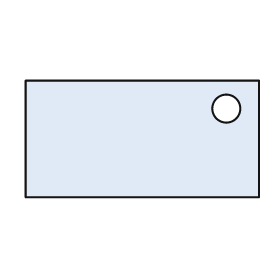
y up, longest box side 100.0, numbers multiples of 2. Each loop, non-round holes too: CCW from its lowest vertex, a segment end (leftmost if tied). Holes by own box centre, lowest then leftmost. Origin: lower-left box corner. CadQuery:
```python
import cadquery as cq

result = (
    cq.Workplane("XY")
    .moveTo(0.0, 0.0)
    .lineTo(100.0, 0.0)
    .lineTo(100.0, 50.0)
    .lineTo(0.0, 50.0)
    .close()
    .moveTo(86.0, 38.0)
    .circle(6.0)
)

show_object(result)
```